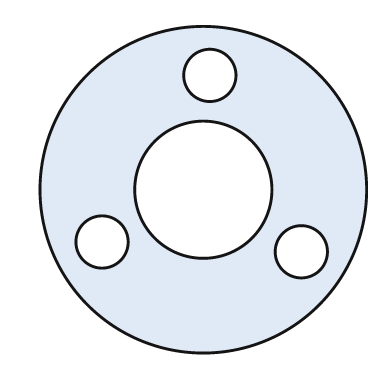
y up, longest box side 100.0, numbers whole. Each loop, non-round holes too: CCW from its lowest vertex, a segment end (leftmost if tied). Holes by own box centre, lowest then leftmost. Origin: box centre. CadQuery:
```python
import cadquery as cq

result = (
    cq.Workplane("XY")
    .moveTo(0.0, 0.0)
    .circle(50.0)
    .moveTo(30.0, -19.0)
    .circle(8.0)
    .moveTo(-31.0, -16.0)
    .circle(8.0)
    .moveTo(0.0, 0.0)
    .circle(21.0)
    .moveTo(2.0, 35.0)
    .circle(8.0)
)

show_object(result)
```